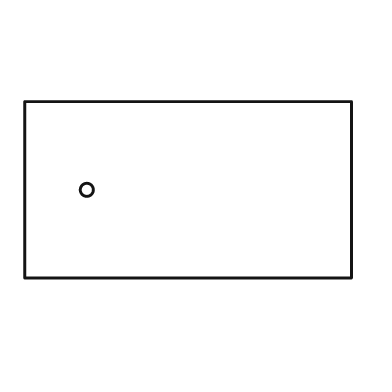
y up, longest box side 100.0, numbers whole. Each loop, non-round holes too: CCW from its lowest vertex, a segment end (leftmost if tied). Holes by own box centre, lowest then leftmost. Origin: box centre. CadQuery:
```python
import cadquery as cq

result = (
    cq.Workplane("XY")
    .moveTo(-50.0, -27.0)
    .lineTo(50.0, -27.0)
    .lineTo(50.0, 27.0)
    .lineTo(-50.0, 27.0)
    .close()
    .moveTo(-31.0, 0.0)
    .circle(2.0)
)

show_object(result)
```